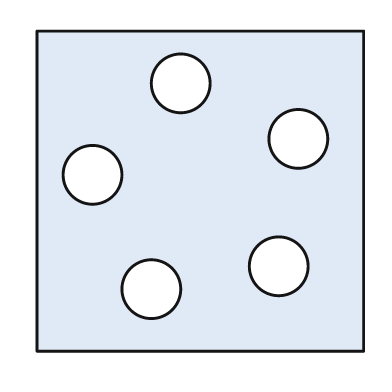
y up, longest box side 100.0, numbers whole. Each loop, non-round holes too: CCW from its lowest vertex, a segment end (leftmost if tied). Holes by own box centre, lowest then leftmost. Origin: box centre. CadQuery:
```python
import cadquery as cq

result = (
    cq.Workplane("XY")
    .moveTo(-50.0, -49.0)
    .lineTo(50.0, -49.0)
    .lineTo(50.0, 49.0)
    .lineTo(-50.0, 49.0)
    .close()
    .moveTo(-15.0, -30.0)
    .circle(9.0)
    .moveTo(24.0, -23.0)
    .circle(9.0)
    .moveTo(-33.0, 5.0)
    .circle(9.0)
    .moveTo(30.0, 16.0)
    .circle(9.0)
    .moveTo(-6.0, 33.0)
    .circle(9.0)
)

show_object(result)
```